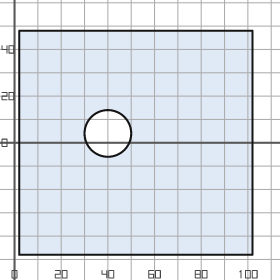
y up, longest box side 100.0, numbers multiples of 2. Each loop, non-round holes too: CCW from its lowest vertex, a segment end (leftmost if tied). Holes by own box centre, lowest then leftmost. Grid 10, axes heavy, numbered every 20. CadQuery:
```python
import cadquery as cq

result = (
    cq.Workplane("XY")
    .moveTo(2.0, -48.0)
    .lineTo(102.0, -48.0)
    .lineTo(102.0, 48.0)
    .lineTo(2.0, 48.0)
    .close()
    .moveTo(40.0, 4.0)
    .circle(10.0)
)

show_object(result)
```